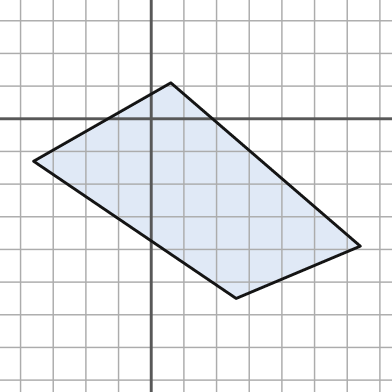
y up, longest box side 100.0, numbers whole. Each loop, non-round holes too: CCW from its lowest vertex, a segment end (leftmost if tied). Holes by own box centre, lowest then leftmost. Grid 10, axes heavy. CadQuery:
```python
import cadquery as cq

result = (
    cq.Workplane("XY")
    .moveTo(26.0, -55.0)
    .lineTo(64.0, -39.0)
    .lineTo(6.0, 11.0)
    .lineTo(-36.0, -13.0)
    .close()
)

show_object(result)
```